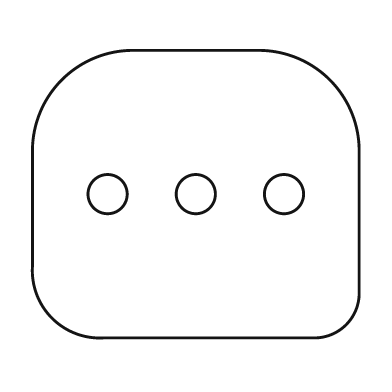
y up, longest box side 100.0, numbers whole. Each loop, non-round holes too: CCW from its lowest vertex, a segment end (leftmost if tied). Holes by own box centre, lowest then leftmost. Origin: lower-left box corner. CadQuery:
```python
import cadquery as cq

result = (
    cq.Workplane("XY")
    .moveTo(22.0, 0.0)
    .lineTo(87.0, 0.0)
    .threePointArc((96.0, 4.0), (100.0, 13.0))
    .lineTo(100.0, 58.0)
    .threePointArc((91.0, 79.0), (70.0, 88.0))
    .lineTo(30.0, 88.0)
    .threePointArc((9.0, 79.0), (0.0, 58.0))
    .lineTo(0.0, 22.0)
    .threePointArc((6.0, 6.0), (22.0, 0.0))
    .close()
    .moveTo(23.0, 44.0)
    .circle(6.0)
    .moveTo(50.0, 44.0)
    .circle(6.0)
    .moveTo(77.0, 44.0)
    .circle(6.0)
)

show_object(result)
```